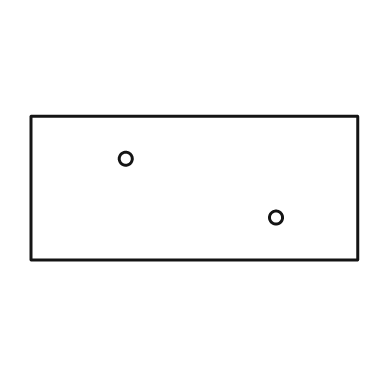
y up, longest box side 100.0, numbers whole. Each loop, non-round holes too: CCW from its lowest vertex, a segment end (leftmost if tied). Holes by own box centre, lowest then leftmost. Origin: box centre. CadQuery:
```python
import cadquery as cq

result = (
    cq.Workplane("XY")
    .moveTo(-50.0, -22.0)
    .lineTo(50.0, -22.0)
    .lineTo(50.0, 22.0)
    .lineTo(-50.0, 22.0)
    .close()
    .moveTo(25.0, -9.0)
    .circle(2.0)
    .moveTo(-21.0, 9.0)
    .circle(2.0)
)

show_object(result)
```